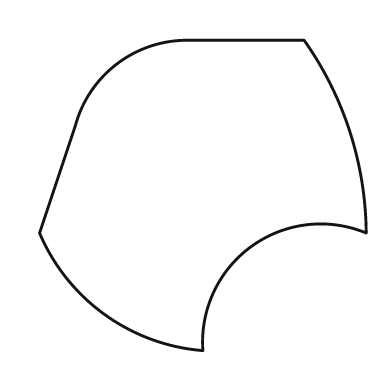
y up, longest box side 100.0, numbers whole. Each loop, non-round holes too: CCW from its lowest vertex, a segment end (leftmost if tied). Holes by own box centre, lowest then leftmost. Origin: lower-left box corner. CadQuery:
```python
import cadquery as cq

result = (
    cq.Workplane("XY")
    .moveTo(50.0, 0.0)
    .threePointArc((65.0, 32.0), (100.0, 36.0))
    .threePointArc((95.0, 67.0), (81.0, 95.0))
    .lineTo(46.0, 95.0)
    .threePointArc((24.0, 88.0), (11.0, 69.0))
    .lineTo(0.0, 36.0)
    .threePointArc((20.0, 11.0), (50.0, 0.0))
    .close()
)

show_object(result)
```